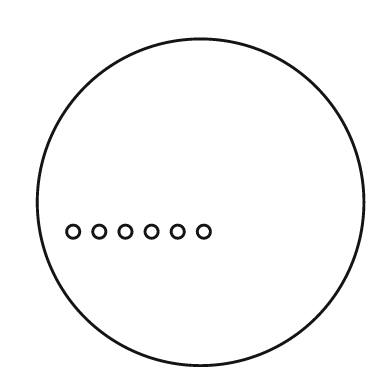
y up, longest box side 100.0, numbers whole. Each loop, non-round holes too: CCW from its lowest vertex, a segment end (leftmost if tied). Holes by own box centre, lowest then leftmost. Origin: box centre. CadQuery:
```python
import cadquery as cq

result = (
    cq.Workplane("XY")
    .moveTo(0.0, 0.0)
    .circle(50.0)
    .moveTo(-39.0, -9.0)
    .circle(2.0)
    .moveTo(-31.0, -9.0)
    .circle(2.0)
    .moveTo(-23.0, -9.0)
    .circle(2.0)
    .moveTo(-15.0, -9.0)
    .circle(2.0)
    .moveTo(-7.0, -9.0)
    .circle(2.0)
    .moveTo(1.0, -9.0)
    .circle(2.0)
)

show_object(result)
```